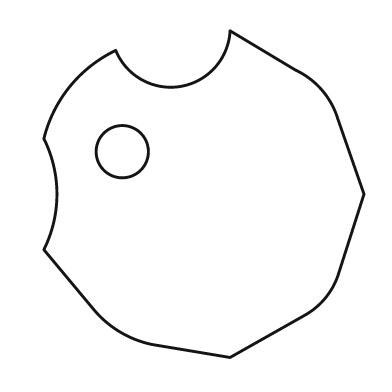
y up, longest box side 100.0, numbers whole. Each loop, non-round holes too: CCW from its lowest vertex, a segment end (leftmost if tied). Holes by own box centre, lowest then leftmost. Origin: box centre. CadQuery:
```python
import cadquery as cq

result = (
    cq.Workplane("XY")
    .moveTo(8.0, -50.0)
    .lineTo(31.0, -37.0)
    .threePointArc((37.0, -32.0), (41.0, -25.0))
    .lineTo(49.0, 0.0)
    .lineTo(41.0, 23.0)
    .threePointArc((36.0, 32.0), (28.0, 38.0))
    .lineTo(8.0, 50.0)
    .threePointArc((-7.0, 33.0), (-27.0, 44.0))
    .threePointArc((-41.0, 33.0), (-49.0, 17.0))
    .threePointArc((-45.0, 0.0), (-49.0, -17.0))
    .lineTo(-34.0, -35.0)
    .threePointArc((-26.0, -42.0), (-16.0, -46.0))
    .close()
    .moveTo(-25.0, 13.0)
    .circle(8.0)
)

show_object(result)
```